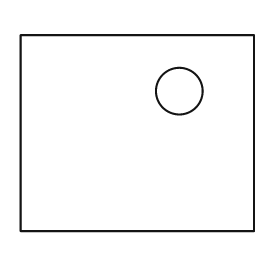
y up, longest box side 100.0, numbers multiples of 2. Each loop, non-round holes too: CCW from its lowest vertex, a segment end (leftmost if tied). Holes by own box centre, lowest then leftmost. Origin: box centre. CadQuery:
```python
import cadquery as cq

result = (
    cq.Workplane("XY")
    .moveTo(-50.0, -42.0)
    .lineTo(50.0, -42.0)
    .lineTo(50.0, 42.0)
    .lineTo(-50.0, 42.0)
    .close()
    .moveTo(18.0, 18.0)
    .circle(10.0)
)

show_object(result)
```